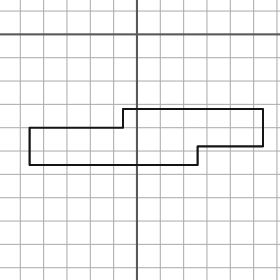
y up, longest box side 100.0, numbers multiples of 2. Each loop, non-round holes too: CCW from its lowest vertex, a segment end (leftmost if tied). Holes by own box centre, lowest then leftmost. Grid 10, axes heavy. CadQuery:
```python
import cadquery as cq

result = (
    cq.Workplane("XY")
    .moveTo(-46.0, -56.0)
    .lineTo(26.0, -56.0)
    .lineTo(26.0, -48.0)
    .lineTo(54.0, -48.0)
    .lineTo(54.0, -32.0)
    .lineTo(-6.0, -32.0)
    .lineTo(-6.0, -40.0)
    .lineTo(-46.0, -40.0)
    .close()
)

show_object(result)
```